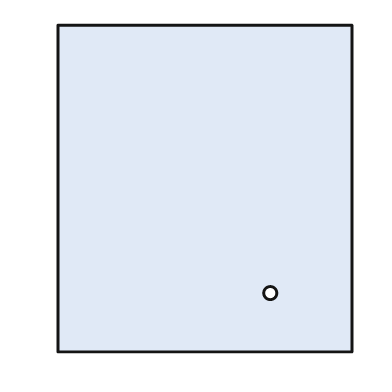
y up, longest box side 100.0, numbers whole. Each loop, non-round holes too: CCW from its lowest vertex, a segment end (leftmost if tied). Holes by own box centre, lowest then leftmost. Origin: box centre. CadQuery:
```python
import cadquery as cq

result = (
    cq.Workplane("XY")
    .moveTo(-45.0, -50.0)
    .lineTo(45.0, -50.0)
    .lineTo(45.0, 50.0)
    .lineTo(-45.0, 50.0)
    .close()
    .moveTo(20.0, -32.0)
    .circle(2.0)
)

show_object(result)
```